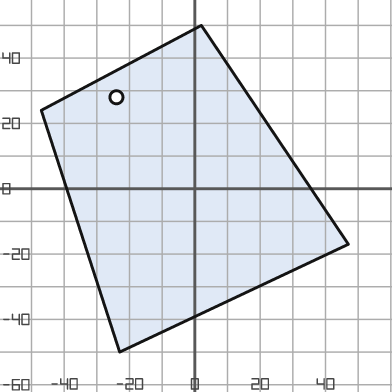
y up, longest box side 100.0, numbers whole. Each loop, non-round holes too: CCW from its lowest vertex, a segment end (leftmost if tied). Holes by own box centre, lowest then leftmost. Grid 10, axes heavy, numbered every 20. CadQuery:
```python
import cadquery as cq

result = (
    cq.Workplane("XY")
    .moveTo(-23.0, -50.0)
    .lineTo(47.0, -17.0)
    .lineTo(2.0, 50.0)
    .lineTo(-47.0, 24.0)
    .close()
    .moveTo(-24.0, 28.0)
    .circle(2.0)
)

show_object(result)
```